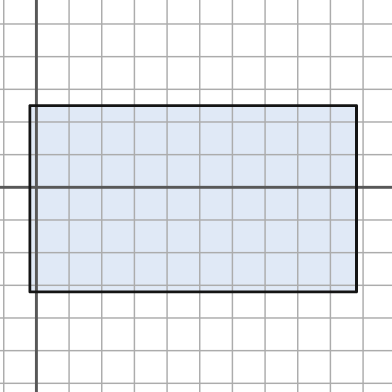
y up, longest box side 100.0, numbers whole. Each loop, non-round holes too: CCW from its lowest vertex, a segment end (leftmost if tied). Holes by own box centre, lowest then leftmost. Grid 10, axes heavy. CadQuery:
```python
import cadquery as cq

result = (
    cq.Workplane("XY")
    .moveTo(-2.0, -32.0)
    .lineTo(98.0, -32.0)
    .lineTo(98.0, 25.0)
    .lineTo(-2.0, 25.0)
    .close()
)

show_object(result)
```